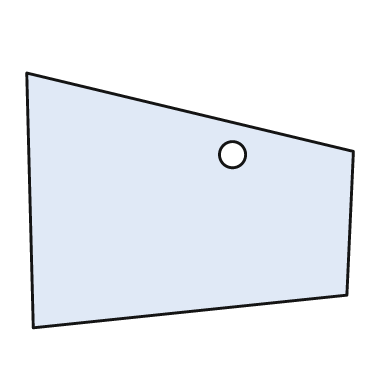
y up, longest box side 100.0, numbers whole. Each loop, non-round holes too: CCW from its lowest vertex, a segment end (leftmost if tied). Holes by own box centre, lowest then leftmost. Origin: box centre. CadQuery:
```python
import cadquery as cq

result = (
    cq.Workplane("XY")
    .moveTo(-48.0, -39.0)
    .lineTo(48.0, -29.0)
    .lineTo(50.0, 15.0)
    .lineTo(-50.0, 39.0)
    .close()
    .moveTo(13.0, 14.0)
    .circle(4.0)
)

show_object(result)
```